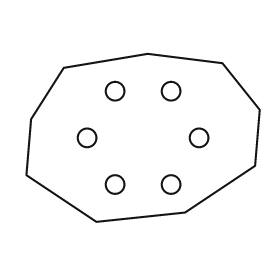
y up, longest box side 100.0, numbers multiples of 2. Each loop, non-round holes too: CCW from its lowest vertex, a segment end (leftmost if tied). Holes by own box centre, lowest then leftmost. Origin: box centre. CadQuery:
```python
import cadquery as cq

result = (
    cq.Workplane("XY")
    .moveTo(-20.0, -36.0)
    .lineTo(18.0, -32.0)
    .lineTo(48.0, -12.0)
    .lineTo(50.0, 12.0)
    .lineTo(34.0, 32.0)
    .lineTo(2.0, 36.0)
    .lineTo(-34.0, 30.0)
    .lineTo(-48.0, 8.0)
    .lineTo(-50.0, -16.0)
    .close()
    .moveTo(-12.0, -20.0)
    .circle(4.0)
    .moveTo(12.0, -20.0)
    .circle(4.0)
    .moveTo(-24.0, 0.0)
    .circle(4.0)
    .moveTo(24.0, 0.0)
    .circle(4.0)
    .moveTo(-12.0, 20.0)
    .circle(4.0)
    .moveTo(12.0, 20.0)
    .circle(4.0)
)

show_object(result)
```